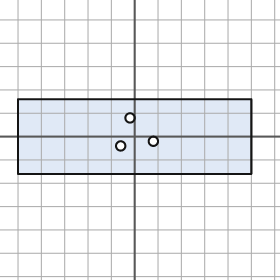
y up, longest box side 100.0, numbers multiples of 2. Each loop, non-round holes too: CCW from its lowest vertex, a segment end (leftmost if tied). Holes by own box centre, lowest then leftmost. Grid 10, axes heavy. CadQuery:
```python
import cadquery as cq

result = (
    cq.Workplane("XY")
    .moveTo(-50.0, -16.0)
    .lineTo(50.0, -16.0)
    .lineTo(50.0, 16.0)
    .lineTo(-50.0, 16.0)
    .close()
    .moveTo(-6.0, -4.0)
    .circle(2.0)
    .moveTo(8.0, -2.0)
    .circle(2.0)
    .moveTo(-2.0, 8.0)
    .circle(2.0)
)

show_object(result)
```